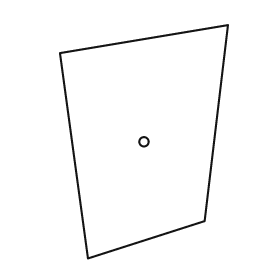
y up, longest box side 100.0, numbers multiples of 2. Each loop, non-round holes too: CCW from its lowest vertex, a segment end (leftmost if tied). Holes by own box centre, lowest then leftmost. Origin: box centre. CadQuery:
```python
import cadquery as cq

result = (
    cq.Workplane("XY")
    .moveTo(-24.0, -50.0)
    .lineTo(26.0, -34.0)
    .lineTo(36.0, 50.0)
    .lineTo(-36.0, 38.0)
    .close()
    .moveTo(0.0, 0.0)
    .circle(2.0)
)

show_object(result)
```